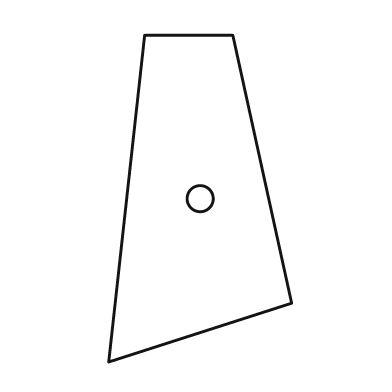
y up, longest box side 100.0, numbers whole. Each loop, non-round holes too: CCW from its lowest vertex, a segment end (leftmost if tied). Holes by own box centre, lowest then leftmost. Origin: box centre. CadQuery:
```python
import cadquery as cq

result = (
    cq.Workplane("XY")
    .moveTo(-28.0, -50.0)
    .lineTo(28.0, -32.0)
    .lineTo(10.0, 50.0)
    .lineTo(-17.0, 50.0)
    .close()
    .moveTo(0.0, 0.0)
    .circle(4.0)
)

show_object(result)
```